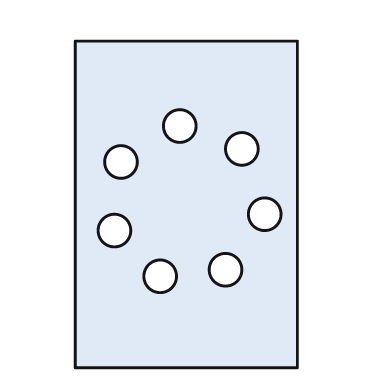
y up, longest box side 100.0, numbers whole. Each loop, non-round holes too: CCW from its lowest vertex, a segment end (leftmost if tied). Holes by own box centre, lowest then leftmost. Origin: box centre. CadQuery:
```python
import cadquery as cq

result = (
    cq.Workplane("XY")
    .moveTo(-34.0, -50.0)
    .lineTo(34.0, -50.0)
    .lineTo(34.0, 50.0)
    .lineTo(-34.0, 50.0)
    .close()
    .moveTo(-8.0, -22.0)
    .circle(5.0)
    .moveTo(12.0, -20.0)
    .circle(5.0)
    .moveTo(-22.0, -8.0)
    .circle(5.0)
    .moveTo(24.0, -3.0)
    .circle(5.0)
    .moveTo(-20.0, 13.0)
    .circle(5.0)
    .moveTo(17.0, 17.0)
    .circle(5.0)
    .moveTo(-2.0, 24.0)
    .circle(5.0)
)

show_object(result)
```